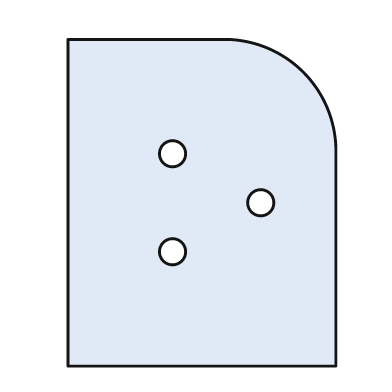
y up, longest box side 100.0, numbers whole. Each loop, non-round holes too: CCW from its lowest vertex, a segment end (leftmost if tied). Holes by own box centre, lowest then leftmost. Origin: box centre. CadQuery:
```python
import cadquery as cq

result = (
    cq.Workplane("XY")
    .moveTo(-41.0, -50.0)
    .lineTo(41.0, -50.0)
    .lineTo(41.0, 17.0)
    .threePointArc((31.0, 40.0), (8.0, 50.0))
    .lineTo(-41.0, 50.0)
    .close()
    .moveTo(-9.0, -15.0)
    .circle(4.0)
    .moveTo(18.0, 0.0)
    .circle(4.0)
    .moveTo(-9.0, 15.0)
    .circle(4.0)
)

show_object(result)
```